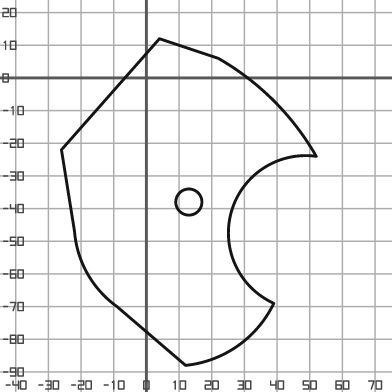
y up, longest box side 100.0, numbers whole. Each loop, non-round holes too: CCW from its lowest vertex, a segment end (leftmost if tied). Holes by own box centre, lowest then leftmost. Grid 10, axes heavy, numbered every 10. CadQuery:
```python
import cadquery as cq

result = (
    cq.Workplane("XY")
    .moveTo(12.0, -88.0)
    .threePointArc((28.0, -82.0), (39.0, -69.0))
    .threePointArc((26.0, -41.0), (52.0, -24.0))
    .threePointArc((39.0, -7.0), (22.0, 6.0))
    .lineTo(4.0, 12.0)
    .lineTo(-26.0, -22.0)
    .lineTo(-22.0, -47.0)
    .threePointArc((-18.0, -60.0), (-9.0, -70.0))
    .close()
    .moveTo(13.0, -38.0)
    .circle(4.0)
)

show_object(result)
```